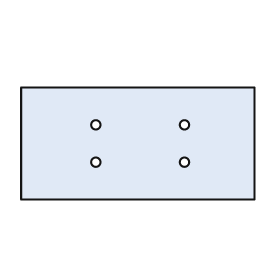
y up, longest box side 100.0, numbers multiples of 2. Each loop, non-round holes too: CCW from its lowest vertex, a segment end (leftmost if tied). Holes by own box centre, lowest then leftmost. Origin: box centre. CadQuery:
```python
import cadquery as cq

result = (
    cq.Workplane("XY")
    .moveTo(-50.0, -24.0)
    .lineTo(50.0, -24.0)
    .lineTo(50.0, 24.0)
    .lineTo(-50.0, 24.0)
    .close()
    .moveTo(-18.0, -8.0)
    .circle(2.0)
    .moveTo(20.0, -8.0)
    .circle(2.0)
    .moveTo(-18.0, 8.0)
    .circle(2.0)
    .moveTo(20.0, 8.0)
    .circle(2.0)
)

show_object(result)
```